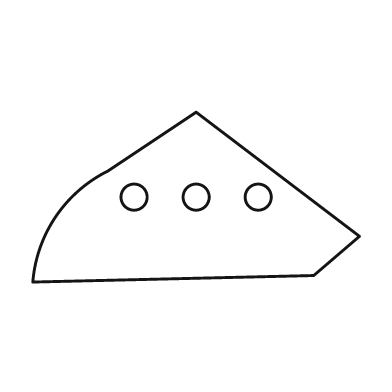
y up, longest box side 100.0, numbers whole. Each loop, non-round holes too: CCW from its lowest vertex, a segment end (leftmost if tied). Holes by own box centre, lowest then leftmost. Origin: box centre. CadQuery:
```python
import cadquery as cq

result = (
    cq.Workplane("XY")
    .moveTo(-50.0, -26.0)
    .lineTo(36.0, -24.0)
    .lineTo(50.0, -12.0)
    .lineTo(0.0, 26.0)
    .lineTo(-27.0, 8.0)
    .threePointArc((-43.0, -6.0), (-50.0, -26.0))
    .close()
    .moveTo(-19.0, 0.0)
    .circle(4.0)
    .moveTo(0.0, 0.0)
    .circle(4.0)
    .moveTo(19.0, 0.0)
    .circle(4.0)
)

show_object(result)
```